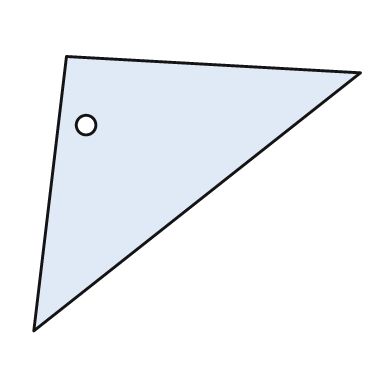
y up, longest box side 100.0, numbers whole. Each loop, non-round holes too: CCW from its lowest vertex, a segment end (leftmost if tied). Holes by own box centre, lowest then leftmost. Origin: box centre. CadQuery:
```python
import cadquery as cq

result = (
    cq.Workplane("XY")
    .moveTo(-50.0, -42.0)
    .lineTo(50.0, 37.0)
    .lineTo(-40.0, 42.0)
    .close()
    .moveTo(-34.0, 21.0)
    .circle(3.0)
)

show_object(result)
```